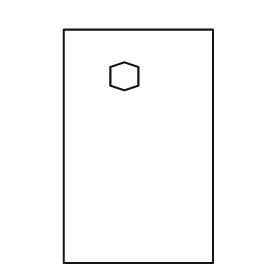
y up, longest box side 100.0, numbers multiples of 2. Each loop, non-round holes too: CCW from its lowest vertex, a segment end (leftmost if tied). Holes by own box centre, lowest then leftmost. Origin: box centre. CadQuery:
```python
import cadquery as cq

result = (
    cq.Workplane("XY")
    .moveTo(-32.0, -50.0)
    .lineTo(32.0, -50.0)
    .lineTo(32.0, 50.0)
    .lineTo(-32.0, 50.0)
    .close()
    .moveTo(-6.0, 24.0)
    .lineTo(0.0, 26.0)
    .lineTo(0.0, 34.0)
    .lineTo(-6.0, 36.0)
    .lineTo(-12.0, 34.0)
    .lineTo(-12.0, 26.0)
    .close()
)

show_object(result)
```